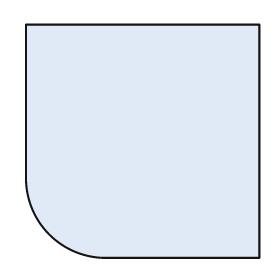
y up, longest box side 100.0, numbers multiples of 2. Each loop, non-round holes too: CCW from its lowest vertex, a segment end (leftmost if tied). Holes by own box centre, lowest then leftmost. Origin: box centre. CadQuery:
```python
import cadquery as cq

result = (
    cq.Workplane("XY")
    .moveTo(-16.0, -50.0)
    .lineTo(50.0, -50.0)
    .lineTo(50.0, 50.0)
    .lineTo(-50.0, 50.0)
    .lineTo(-50.0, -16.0)
    .threePointArc((-40.0, -40.0), (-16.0, -50.0))
    .close()
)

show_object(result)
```